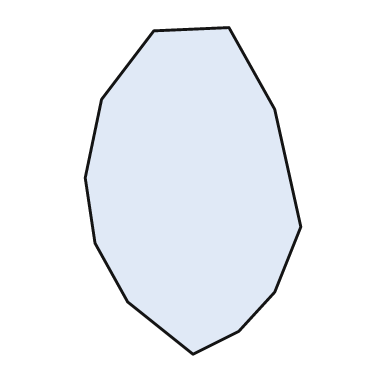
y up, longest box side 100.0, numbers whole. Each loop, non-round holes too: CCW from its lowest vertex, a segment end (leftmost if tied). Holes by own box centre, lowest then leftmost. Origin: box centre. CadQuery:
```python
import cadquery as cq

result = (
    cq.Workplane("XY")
    .moveTo(0.0, -50.0)
    .lineTo(14.0, -43.0)
    .lineTo(25.0, -31.0)
    .lineTo(33.0, -11.0)
    .lineTo(25.0, 25.0)
    .lineTo(11.0, 50.0)
    .lineTo(-12.0, 49.0)
    .lineTo(-28.0, 28.0)
    .lineTo(-33.0, 4.0)
    .lineTo(-30.0, -16.0)
    .lineTo(-20.0, -34.0)
    .close()
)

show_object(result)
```